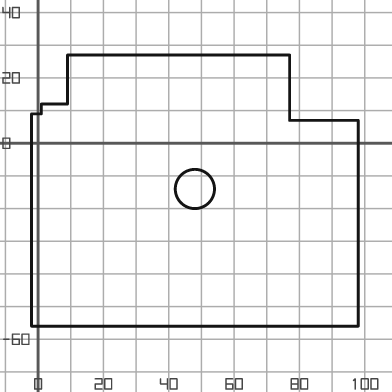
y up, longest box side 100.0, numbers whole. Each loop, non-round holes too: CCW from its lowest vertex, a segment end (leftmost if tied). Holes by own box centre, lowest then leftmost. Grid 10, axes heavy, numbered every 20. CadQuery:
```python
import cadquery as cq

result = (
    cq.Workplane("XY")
    .moveTo(-2.0, -56.0)
    .lineTo(98.0, -56.0)
    .lineTo(98.0, 7.0)
    .lineTo(77.0, 7.0)
    .lineTo(77.0, 27.0)
    .lineTo(9.0, 27.0)
    .lineTo(9.0, 12.0)
    .lineTo(1.0, 12.0)
    .lineTo(1.0, 9.0)
    .lineTo(-2.0, 9.0)
    .close()
    .moveTo(48.0, -14.0)
    .circle(6.0)
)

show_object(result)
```